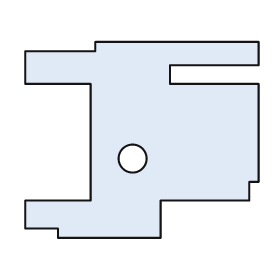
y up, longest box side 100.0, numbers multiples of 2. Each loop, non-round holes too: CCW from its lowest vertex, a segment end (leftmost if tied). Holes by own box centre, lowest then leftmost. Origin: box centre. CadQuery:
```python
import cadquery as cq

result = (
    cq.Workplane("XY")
    .moveTo(-36.0, -42.0)
    .lineTo(8.0, -42.0)
    .lineTo(8.0, -26.0)
    .lineTo(46.0, -26.0)
    .lineTo(46.0, -18.0)
    .lineTo(50.0, -18.0)
    .lineTo(50.0, 24.0)
    .lineTo(12.0, 24.0)
    .lineTo(12.0, 32.0)
    .lineTo(50.0, 32.0)
    .lineTo(50.0, 42.0)
    .lineTo(-20.0, 42.0)
    .lineTo(-20.0, 38.0)
    .lineTo(-50.0, 38.0)
    .lineTo(-50.0, 24.0)
    .lineTo(-22.0, 24.0)
    .lineTo(-22.0, -26.0)
    .lineTo(-50.0, -26.0)
    .lineTo(-50.0, -38.0)
    .lineTo(-36.0, -38.0)
    .close()
    .moveTo(-4.0, -8.0)
    .circle(6.0)
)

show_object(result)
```